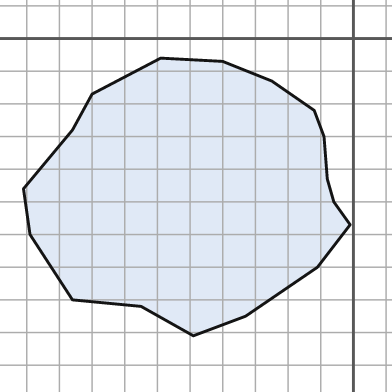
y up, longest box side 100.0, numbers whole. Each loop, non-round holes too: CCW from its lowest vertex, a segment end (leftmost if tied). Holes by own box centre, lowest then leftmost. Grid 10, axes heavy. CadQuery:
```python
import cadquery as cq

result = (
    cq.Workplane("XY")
    .moveTo(-49.0, -91.0)
    .lineTo(-33.0, -85.0)
    .lineTo(-11.0, -70.0)
    .lineTo(-1.0, -57.0)
    .lineTo(-6.0, -50.0)
    .lineTo(-8.0, -43.0)
    .lineTo(-9.0, -30.0)
    .lineTo(-12.0, -22.0)
    .lineTo(-25.0, -13.0)
    .lineTo(-40.0, -7.0)
    .lineTo(-59.0, -6.0)
    .lineTo(-80.0, -17.0)
    .lineTo(-86.0, -28.0)
    .lineTo(-101.0, -46.0)
    .lineTo(-99.0, -60.0)
    .lineTo(-86.0, -80.0)
    .lineTo(-65.0, -82.0)
    .close()
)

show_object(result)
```